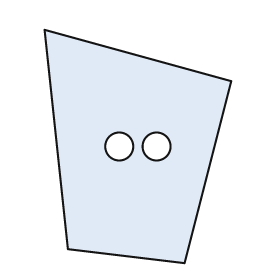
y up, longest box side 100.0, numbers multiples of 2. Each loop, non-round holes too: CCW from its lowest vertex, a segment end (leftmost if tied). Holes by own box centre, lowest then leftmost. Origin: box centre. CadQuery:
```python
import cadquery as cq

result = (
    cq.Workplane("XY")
    .moveTo(20.0, -50.0)
    .lineTo(40.0, 28.0)
    .lineTo(-40.0, 50.0)
    .lineTo(-30.0, -44.0)
    .close()
    .moveTo(-8.0, 0.0)
    .circle(6.0)
    .moveTo(8.0, 0.0)
    .circle(6.0)
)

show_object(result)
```